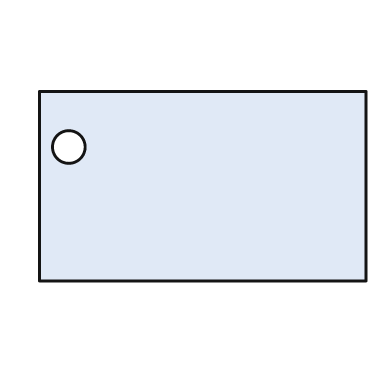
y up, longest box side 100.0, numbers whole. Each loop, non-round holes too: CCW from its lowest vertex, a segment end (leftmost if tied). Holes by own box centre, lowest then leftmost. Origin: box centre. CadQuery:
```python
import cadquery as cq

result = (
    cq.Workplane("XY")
    .moveTo(-50.0, -29.0)
    .lineTo(50.0, -29.0)
    .lineTo(50.0, 29.0)
    .lineTo(-50.0, 29.0)
    .close()
    .moveTo(-41.0, 12.0)
    .circle(5.0)
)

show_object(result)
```